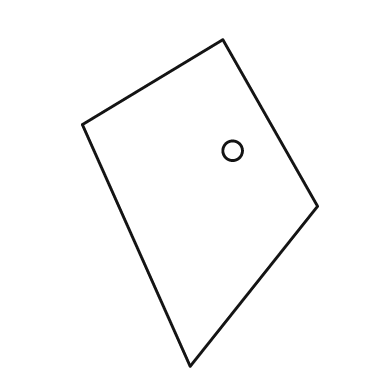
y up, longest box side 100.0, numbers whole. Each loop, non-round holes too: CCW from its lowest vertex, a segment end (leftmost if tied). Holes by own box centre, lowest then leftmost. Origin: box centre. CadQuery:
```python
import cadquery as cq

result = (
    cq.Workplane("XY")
    .moveTo(-3.0, -50.0)
    .lineTo(36.0, -1.0)
    .lineTo(7.0, 50.0)
    .lineTo(-36.0, 24.0)
    .close()
    .moveTo(10.0, 16.0)
    .circle(3.0)
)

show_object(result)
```